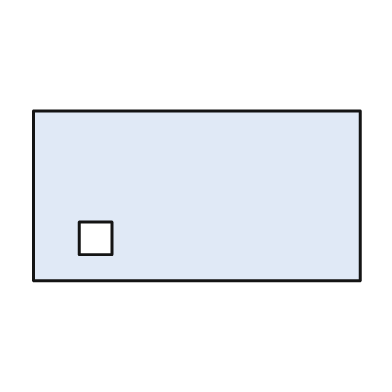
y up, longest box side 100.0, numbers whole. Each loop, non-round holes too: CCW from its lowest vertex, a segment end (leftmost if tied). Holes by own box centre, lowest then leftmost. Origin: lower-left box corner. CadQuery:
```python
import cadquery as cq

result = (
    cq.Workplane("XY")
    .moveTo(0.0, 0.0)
    .lineTo(100.0, 0.0)
    .lineTo(100.0, 52.0)
    .lineTo(0.0, 52.0)
    .close()
    .moveTo(14.0, 8.0)
    .lineTo(24.0, 8.0)
    .lineTo(24.0, 18.0)
    .lineTo(14.0, 18.0)
    .close()
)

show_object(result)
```